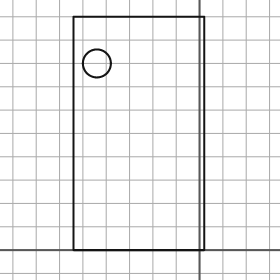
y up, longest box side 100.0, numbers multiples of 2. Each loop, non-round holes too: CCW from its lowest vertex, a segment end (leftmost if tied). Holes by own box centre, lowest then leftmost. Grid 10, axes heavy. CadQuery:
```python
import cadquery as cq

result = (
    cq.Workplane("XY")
    .moveTo(-54.0, 0.0)
    .lineTo(2.0, 0.0)
    .lineTo(2.0, 100.0)
    .lineTo(-54.0, 100.0)
    .close()
    .moveTo(-44.0, 80.0)
    .circle(6.0)
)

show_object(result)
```